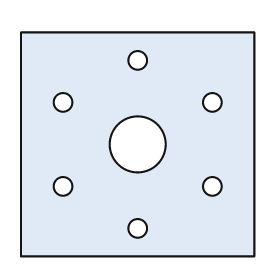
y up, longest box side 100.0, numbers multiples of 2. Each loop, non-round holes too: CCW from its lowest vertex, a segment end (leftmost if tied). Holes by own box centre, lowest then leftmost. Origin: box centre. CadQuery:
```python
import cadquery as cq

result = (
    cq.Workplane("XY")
    .moveTo(-50.0, -48.0)
    .lineTo(50.0, -48.0)
    .lineTo(50.0, 48.0)
    .lineTo(-50.0, 48.0)
    .close()
    .moveTo(0.0, -36.0)
    .circle(4.0)
    .moveTo(-32.0, -18.0)
    .circle(4.0)
    .moveTo(32.0, -18.0)
    .circle(4.0)
    .moveTo(0.0, 0.0)
    .circle(12.0)
    .moveTo(-32.0, 18.0)
    .circle(4.0)
    .moveTo(32.0, 18.0)
    .circle(4.0)
    .moveTo(0.0, 36.0)
    .circle(4.0)
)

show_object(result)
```